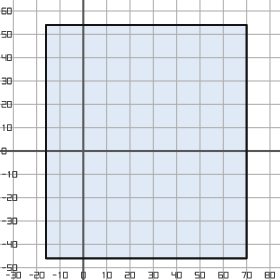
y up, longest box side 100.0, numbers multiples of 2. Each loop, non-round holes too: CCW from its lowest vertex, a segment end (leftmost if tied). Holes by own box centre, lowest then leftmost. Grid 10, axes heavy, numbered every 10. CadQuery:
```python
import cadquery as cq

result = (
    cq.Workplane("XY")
    .moveTo(-16.0, -46.0)
    .lineTo(70.0, -46.0)
    .lineTo(70.0, 54.0)
    .lineTo(-16.0, 54.0)
    .close()
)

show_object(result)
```